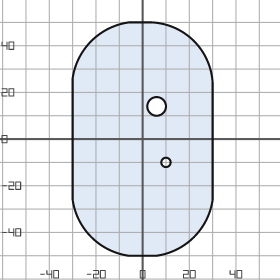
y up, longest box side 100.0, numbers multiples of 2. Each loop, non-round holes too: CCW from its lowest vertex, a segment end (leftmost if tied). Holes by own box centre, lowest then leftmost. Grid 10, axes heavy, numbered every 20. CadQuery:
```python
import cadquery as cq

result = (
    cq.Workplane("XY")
    .moveTo(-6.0, -50.0)
    .lineTo(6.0, -50.0)
    .threePointArc((22.0, -42.0), (30.0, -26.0))
    .lineTo(30.0, 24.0)
    .threePointArc((22.0, 42.0), (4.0, 50.0))
    .lineTo(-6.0, 50.0)
    .threePointArc((-22.0, 42.0), (-30.0, 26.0))
    .lineTo(-30.0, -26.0)
    .threePointArc((-22.0, -42.0), (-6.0, -50.0))
    .close()
    .moveTo(10.0, -10.0)
    .circle(2.0)
    .moveTo(6.0, 14.0)
    .circle(4.0)
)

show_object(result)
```